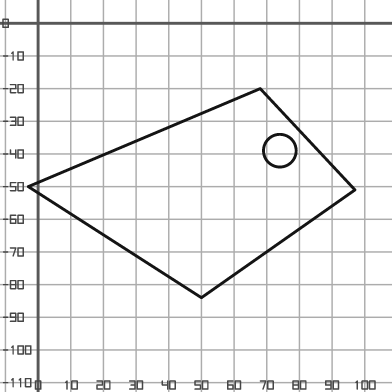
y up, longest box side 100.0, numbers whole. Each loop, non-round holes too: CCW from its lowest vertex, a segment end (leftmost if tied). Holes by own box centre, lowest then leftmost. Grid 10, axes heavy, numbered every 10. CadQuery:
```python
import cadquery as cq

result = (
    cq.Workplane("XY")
    .moveTo(50.0, -84.0)
    .lineTo(97.0, -51.0)
    .lineTo(68.0, -20.0)
    .lineTo(-3.0, -50.0)
    .close()
    .moveTo(74.0, -39.0)
    .circle(5.0)
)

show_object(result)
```